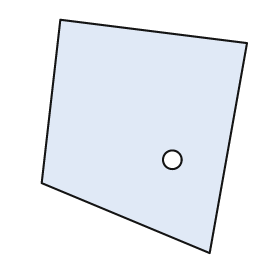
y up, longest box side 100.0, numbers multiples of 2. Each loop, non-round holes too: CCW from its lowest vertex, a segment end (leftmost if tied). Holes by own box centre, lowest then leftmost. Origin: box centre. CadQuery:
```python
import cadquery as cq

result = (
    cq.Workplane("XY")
    .moveTo(28.0, -50.0)
    .lineTo(44.0, 40.0)
    .lineTo(-36.0, 50.0)
    .lineTo(-44.0, -20.0)
    .close()
    .moveTo(12.0, -10.0)
    .circle(4.0)
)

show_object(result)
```